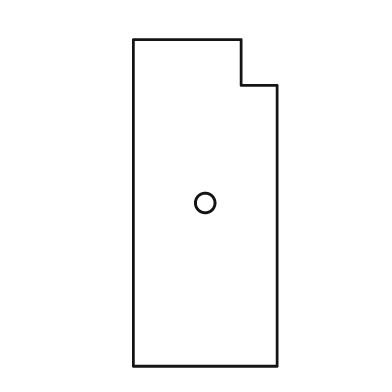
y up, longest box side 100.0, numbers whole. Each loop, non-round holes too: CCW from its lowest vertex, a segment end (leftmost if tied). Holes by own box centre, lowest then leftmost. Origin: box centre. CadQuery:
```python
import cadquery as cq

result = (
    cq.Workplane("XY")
    .moveTo(-22.0, -50.0)
    .lineTo(22.0, -50.0)
    .lineTo(22.0, 36.0)
    .lineTo(11.0, 36.0)
    .lineTo(11.0, 50.0)
    .lineTo(-22.0, 50.0)
    .close()
    .moveTo(0.0, 0.0)
    .circle(3.0)
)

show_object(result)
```